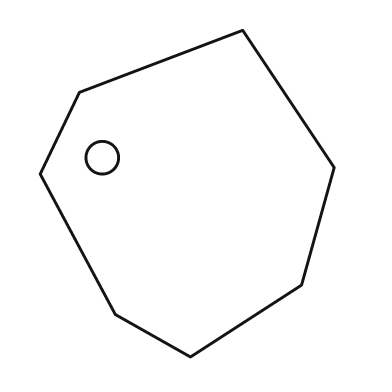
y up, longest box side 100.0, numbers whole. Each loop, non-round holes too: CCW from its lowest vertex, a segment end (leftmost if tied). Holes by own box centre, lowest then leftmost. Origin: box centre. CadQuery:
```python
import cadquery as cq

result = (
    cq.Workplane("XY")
    .moveTo(1.0, -50.0)
    .lineTo(35.0, -28.0)
    .lineTo(45.0, 8.0)
    .lineTo(17.0, 50.0)
    .lineTo(-33.0, 31.0)
    .lineTo(-45.0, 6.0)
    .lineTo(-22.0, -37.0)
    .close()
    .moveTo(-26.0, 11.0)
    .circle(5.0)
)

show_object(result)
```